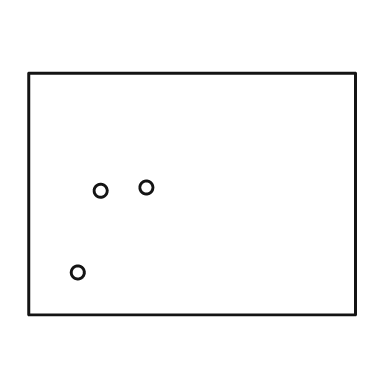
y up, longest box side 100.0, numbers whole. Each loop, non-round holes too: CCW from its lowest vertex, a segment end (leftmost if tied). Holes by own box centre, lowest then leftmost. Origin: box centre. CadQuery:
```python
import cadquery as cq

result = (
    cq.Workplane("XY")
    .moveTo(-50.0, -37.0)
    .lineTo(50.0, -37.0)
    .lineTo(50.0, 37.0)
    .lineTo(-50.0, 37.0)
    .close()
    .moveTo(-35.0, -24.0)
    .circle(2.0)
    .moveTo(-28.0, 1.0)
    .circle(2.0)
    .moveTo(-14.0, 2.0)
    .circle(2.0)
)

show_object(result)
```